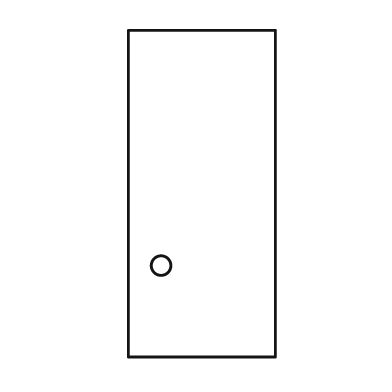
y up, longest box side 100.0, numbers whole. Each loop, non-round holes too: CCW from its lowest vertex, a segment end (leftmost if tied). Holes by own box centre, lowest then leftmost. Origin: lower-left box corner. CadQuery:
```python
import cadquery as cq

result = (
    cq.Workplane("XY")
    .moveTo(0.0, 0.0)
    .lineTo(45.0, 0.0)
    .lineTo(45.0, 100.0)
    .lineTo(0.0, 100.0)
    .close()
    .moveTo(10.0, 28.0)
    .circle(3.0)
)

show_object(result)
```